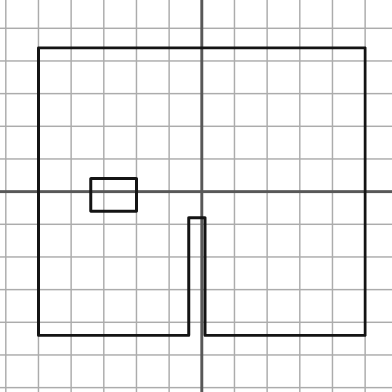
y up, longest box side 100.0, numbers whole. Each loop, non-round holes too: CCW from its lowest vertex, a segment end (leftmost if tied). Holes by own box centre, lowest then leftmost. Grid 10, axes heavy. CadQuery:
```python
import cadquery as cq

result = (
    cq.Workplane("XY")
    .moveTo(-50.0, -44.0)
    .lineTo(-4.0, -44.0)
    .lineTo(-4.0, -8.0)
    .lineTo(1.0, -8.0)
    .lineTo(1.0, -44.0)
    .lineTo(50.0, -44.0)
    .lineTo(50.0, 44.0)
    .lineTo(-50.0, 44.0)
    .close()
    .moveTo(-34.0, -6.0)
    .lineTo(-20.0, -6.0)
    .lineTo(-20.0, 4.0)
    .lineTo(-34.0, 4.0)
    .close()
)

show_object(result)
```